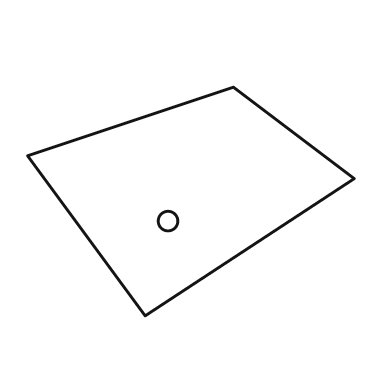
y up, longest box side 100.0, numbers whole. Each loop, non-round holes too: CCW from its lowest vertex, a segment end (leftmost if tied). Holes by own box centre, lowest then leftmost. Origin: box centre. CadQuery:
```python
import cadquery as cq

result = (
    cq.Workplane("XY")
    .moveTo(-14.0, -35.0)
    .lineTo(50.0, 7.0)
    .lineTo(13.0, 35.0)
    .lineTo(-50.0, 14.0)
    .close()
    .moveTo(-7.0, -6.0)
    .circle(3.0)
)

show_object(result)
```